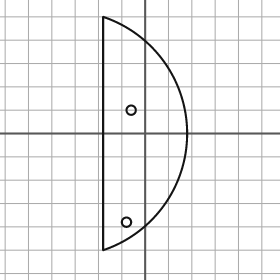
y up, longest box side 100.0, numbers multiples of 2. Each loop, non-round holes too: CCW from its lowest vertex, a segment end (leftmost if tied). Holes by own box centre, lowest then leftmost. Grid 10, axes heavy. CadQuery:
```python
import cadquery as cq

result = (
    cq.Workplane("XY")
    .moveTo(-18.0, -50.0)
    .threePointArc((18.0, 0.0), (-18.0, 50.0))
    .close()
    .moveTo(-8.0, -38.0)
    .circle(2.0)
    .moveTo(-6.0, 10.0)
    .circle(2.0)
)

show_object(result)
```